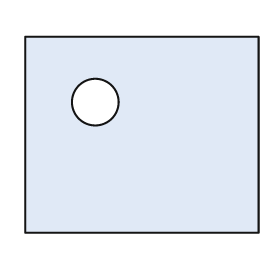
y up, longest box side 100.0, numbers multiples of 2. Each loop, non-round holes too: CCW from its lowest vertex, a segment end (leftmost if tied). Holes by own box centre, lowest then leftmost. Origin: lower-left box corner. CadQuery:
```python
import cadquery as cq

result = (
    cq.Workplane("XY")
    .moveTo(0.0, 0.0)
    .lineTo(100.0, 0.0)
    .lineTo(100.0, 84.0)
    .lineTo(0.0, 84.0)
    .close()
    .moveTo(30.0, 56.0)
    .circle(10.0)
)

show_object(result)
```